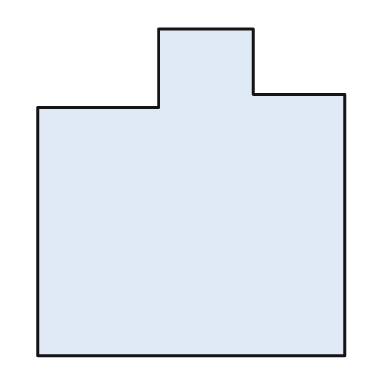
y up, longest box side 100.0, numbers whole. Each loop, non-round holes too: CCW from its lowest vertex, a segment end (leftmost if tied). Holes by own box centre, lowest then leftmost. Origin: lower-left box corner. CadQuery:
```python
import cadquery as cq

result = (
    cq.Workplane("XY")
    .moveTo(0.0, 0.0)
    .lineTo(94.0, 0.0)
    .lineTo(94.0, 80.0)
    .lineTo(66.0, 80.0)
    .lineTo(66.0, 100.0)
    .lineTo(37.0, 100.0)
    .lineTo(37.0, 76.0)
    .lineTo(0.0, 76.0)
    .close()
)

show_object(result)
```